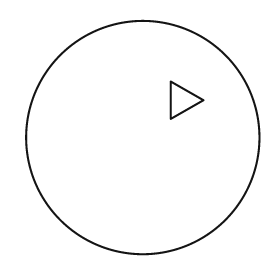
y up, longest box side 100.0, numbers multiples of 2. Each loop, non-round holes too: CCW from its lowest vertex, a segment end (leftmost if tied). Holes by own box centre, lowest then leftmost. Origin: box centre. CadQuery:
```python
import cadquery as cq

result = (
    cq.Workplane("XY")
    .moveTo(0.0, 0.0)
    .circle(50.0)
    .moveTo(12.0, 8.0)
    .lineTo(26.0, 16.0)
    .lineTo(12.0, 24.0)
    .close()
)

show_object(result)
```